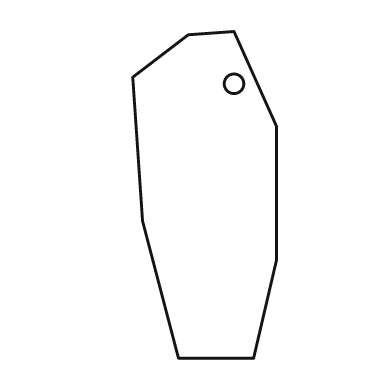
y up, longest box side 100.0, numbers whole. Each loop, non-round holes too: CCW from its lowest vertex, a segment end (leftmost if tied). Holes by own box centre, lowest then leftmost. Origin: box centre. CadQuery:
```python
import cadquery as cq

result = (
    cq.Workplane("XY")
    .moveTo(-8.0, -50.0)
    .lineTo(15.0, -50.0)
    .lineTo(22.0, -20.0)
    .lineTo(22.0, 21.0)
    .lineTo(9.0, 50.0)
    .lineTo(-5.0, 49.0)
    .lineTo(-22.0, 36.0)
    .lineTo(-19.0, -8.0)
    .close()
    .moveTo(9.0, 34.0)
    .circle(3.0)
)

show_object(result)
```